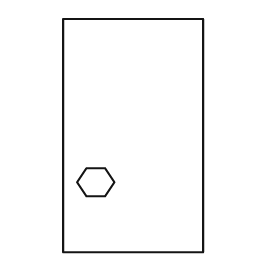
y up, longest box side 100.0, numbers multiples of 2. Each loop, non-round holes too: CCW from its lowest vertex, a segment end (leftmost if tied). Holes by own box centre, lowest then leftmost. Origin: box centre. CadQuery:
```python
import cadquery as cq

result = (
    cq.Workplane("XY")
    .moveTo(-30.0, -50.0)
    .lineTo(30.0, -50.0)
    .lineTo(30.0, 50.0)
    .lineTo(-30.0, 50.0)
    .close()
    .moveTo(-20.0, -26.0)
    .lineTo(-12.0, -26.0)
    .lineTo(-8.0, -20.0)
    .lineTo(-12.0, -14.0)
    .lineTo(-20.0, -14.0)
    .lineTo(-24.0, -20.0)
    .close()
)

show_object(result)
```